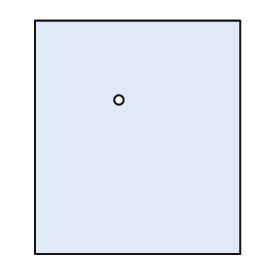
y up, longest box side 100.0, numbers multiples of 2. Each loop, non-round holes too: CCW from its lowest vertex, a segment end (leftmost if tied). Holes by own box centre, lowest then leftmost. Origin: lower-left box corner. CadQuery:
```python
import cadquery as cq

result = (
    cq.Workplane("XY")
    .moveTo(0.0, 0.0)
    .lineTo(88.0, 0.0)
    .lineTo(88.0, 100.0)
    .lineTo(0.0, 100.0)
    .close()
    .moveTo(36.0, 66.0)
    .circle(2.0)
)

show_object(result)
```